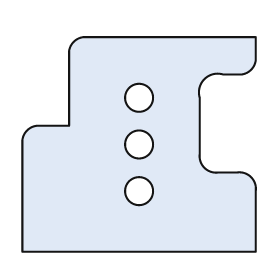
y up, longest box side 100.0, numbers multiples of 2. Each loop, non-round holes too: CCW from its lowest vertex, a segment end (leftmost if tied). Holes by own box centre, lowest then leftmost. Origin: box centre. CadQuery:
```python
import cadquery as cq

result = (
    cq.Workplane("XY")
    .moveTo(-50.0, -46.0)
    .lineTo(50.0, -46.0)
    .lineTo(50.0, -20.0)
    .threePointArc((48.0, -14.0), (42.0, -12.0))
    .lineTo(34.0, -12.0)
    .threePointArc((28.0, -10.0), (26.0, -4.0))
    .lineTo(26.0, 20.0)
    .threePointArc((28.0, 28.0), (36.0, 30.0))
    .lineTo(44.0, 30.0)
    .threePointArc((48.0, 32.0), (50.0, 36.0))
    .lineTo(50.0, 46.0)
    .lineTo(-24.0, 46.0)
    .threePointArc((-28.0, 44.0), (-30.0, 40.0))
    .lineTo(-30.0, 8.0)
    .lineTo(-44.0, 8.0)
    .threePointArc((-48.0, 6.0), (-50.0, 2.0))
    .close()
    .moveTo(0.0, -20.0)
    .circle(6.0)
    .moveTo(0.0, 0.0)
    .circle(6.0)
    .moveTo(0.0, 20.0)
    .circle(6.0)
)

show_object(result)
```